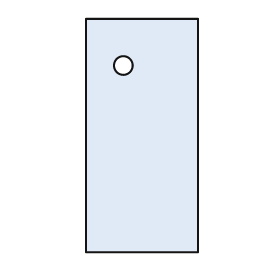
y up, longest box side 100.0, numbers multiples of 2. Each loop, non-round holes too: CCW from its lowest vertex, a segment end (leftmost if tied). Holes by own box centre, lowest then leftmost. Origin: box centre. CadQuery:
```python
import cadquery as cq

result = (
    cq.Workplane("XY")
    .moveTo(-24.0, -50.0)
    .lineTo(24.0, -50.0)
    .lineTo(24.0, 50.0)
    .lineTo(-24.0, 50.0)
    .close()
    .moveTo(-8.0, 30.0)
    .circle(4.0)
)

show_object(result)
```